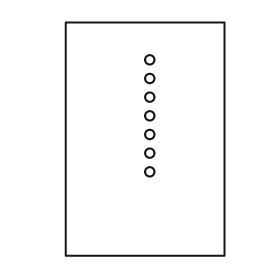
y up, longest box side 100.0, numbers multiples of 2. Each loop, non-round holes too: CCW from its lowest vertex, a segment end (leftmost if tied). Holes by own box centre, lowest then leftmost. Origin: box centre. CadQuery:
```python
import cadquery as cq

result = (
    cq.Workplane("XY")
    .moveTo(-34.0, -50.0)
    .lineTo(34.0, -50.0)
    .lineTo(34.0, 50.0)
    .lineTo(-34.0, 50.0)
    .close()
    .moveTo(2.0, -14.0)
    .circle(2.0)
    .moveTo(2.0, -6.0)
    .circle(2.0)
    .moveTo(2.0, 2.0)
    .circle(2.0)
    .moveTo(2.0, 10.0)
    .circle(2.0)
    .moveTo(2.0, 18.0)
    .circle(2.0)
    .moveTo(2.0, 26.0)
    .circle(2.0)
    .moveTo(2.0, 34.0)
    .circle(2.0)
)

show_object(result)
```